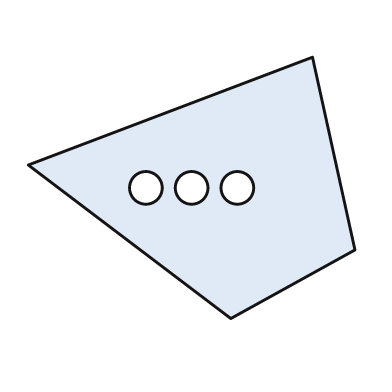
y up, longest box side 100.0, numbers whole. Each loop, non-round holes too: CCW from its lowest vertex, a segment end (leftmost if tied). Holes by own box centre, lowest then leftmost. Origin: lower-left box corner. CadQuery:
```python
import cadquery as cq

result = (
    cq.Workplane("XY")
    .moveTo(62.0, 0.0)
    .lineTo(100.0, 21.0)
    .lineTo(87.0, 80.0)
    .lineTo(0.0, 47.0)
    .close()
    .moveTo(36.0, 40.0)
    .circle(5.0)
    .moveTo(50.0, 40.0)
    .circle(5.0)
    .moveTo(64.0, 40.0)
    .circle(5.0)
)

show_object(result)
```